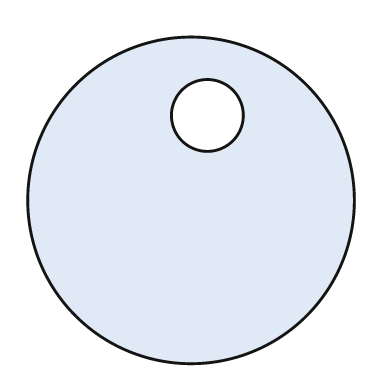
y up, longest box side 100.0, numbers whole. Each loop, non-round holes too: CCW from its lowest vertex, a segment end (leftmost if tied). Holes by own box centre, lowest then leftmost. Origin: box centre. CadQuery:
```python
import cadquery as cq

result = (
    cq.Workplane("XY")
    .moveTo(0.0, 0.0)
    .circle(50.0)
    .moveTo(5.0, 26.0)
    .circle(11.0)
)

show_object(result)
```